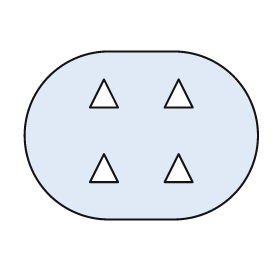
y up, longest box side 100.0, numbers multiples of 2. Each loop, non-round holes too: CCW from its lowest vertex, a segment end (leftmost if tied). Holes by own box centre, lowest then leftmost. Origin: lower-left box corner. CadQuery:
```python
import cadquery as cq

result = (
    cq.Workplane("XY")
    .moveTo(36.0, 0.0)
    .lineTo(64.0, 0.0)
    .threePointArc((100.0, 36.0), (64.0, 72.0))
    .lineTo(36.0, 72.0)
    .threePointArc((0.0, 36.0), (36.0, 0.0))
    .close()
    .moveTo(28.0, 16.0)
    .lineTo(40.0, 16.0)
    .lineTo(34.0, 28.0)
    .close()
    .moveTo(60.0, 16.0)
    .lineTo(72.0, 16.0)
    .lineTo(66.0, 28.0)
    .close()
    .moveTo(28.0, 48.0)
    .lineTo(40.0, 48.0)
    .lineTo(34.0, 60.0)
    .close()
    .moveTo(60.0, 48.0)
    .lineTo(72.0, 48.0)
    .lineTo(66.0, 60.0)
    .close()
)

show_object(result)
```